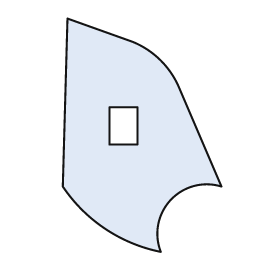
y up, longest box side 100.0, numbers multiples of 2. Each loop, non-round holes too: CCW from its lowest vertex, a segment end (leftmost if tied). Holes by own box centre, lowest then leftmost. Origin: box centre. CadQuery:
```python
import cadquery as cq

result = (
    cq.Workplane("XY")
    .moveTo(8.0, -50.0)
    .threePointArc((12.0, -28.0), (34.0, -22.0))
    .lineTo(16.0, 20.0)
    .threePointArc((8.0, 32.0), (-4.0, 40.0))
    .lineTo(-32.0, 50.0)
    .lineTo(-34.0, -22.0)
    .threePointArc((-16.0, -40.0), (8.0, -50.0))
    .close()
    .moveTo(-14.0, -4.0)
    .lineTo(-2.0, -4.0)
    .lineTo(-2.0, 12.0)
    .lineTo(-14.0, 12.0)
    .close()
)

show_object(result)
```